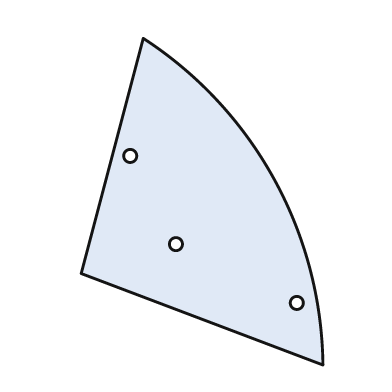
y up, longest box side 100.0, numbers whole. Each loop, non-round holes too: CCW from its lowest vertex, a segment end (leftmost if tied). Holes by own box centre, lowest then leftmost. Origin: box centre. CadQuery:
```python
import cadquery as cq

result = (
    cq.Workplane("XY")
    .moveTo(37.0, -50.0)
    .threePointArc((22.0, 7.0), (-18.0, 50.0))
    .lineTo(-37.0, -22.0)
    .close()
    .moveTo(29.0, -31.0)
    .circle(2.0)
    .moveTo(-8.0, -13.0)
    .circle(2.0)
    .moveTo(-22.0, 14.0)
    .circle(2.0)
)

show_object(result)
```